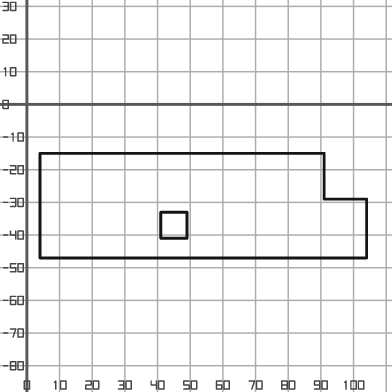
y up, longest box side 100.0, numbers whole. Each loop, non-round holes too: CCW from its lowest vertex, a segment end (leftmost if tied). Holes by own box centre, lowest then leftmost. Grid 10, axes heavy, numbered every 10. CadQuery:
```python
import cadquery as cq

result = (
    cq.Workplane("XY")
    .moveTo(4.0, -47.0)
    .lineTo(104.0, -47.0)
    .lineTo(104.0, -29.0)
    .lineTo(91.0, -29.0)
    .lineTo(91.0, -15.0)
    .lineTo(4.0, -15.0)
    .close()
    .moveTo(41.0, -41.0)
    .lineTo(49.0, -41.0)
    .lineTo(49.0, -33.0)
    .lineTo(41.0, -33.0)
    .close()
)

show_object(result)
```